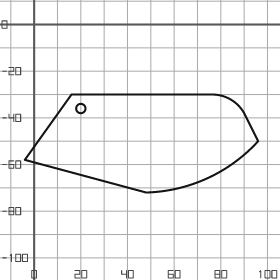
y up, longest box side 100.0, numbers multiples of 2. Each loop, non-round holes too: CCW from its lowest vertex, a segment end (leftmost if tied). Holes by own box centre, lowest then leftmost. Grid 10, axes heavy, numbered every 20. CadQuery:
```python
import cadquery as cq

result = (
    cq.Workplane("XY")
    .moveTo(48.0, -72.0)
    .threePointArc((74.0, -66.0), (96.0, -50.0))
    .lineTo(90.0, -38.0)
    .threePointArc((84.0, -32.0), (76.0, -30.0))
    .lineTo(16.0, -30.0)
    .lineTo(-4.0, -58.0)
    .close()
    .moveTo(20.0, -36.0)
    .circle(2.0)
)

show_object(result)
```